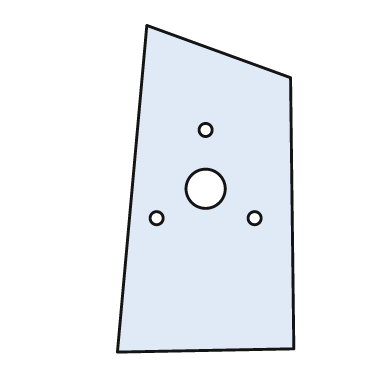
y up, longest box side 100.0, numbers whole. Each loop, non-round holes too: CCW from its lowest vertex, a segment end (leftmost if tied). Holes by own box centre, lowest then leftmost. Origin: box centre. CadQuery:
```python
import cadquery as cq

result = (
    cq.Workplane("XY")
    .moveTo(-27.0, -50.0)
    .lineTo(27.0, -49.0)
    .lineTo(26.0, 34.0)
    .lineTo(-18.0, 50.0)
    .close()
    .moveTo(-15.0, -9.0)
    .circle(2.0)
    .moveTo(15.0, -9.0)
    .circle(2.0)
    .moveTo(0.0, 0.0)
    .circle(6.0)
    .moveTo(0.0, 18.0)
    .circle(2.0)
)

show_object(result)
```